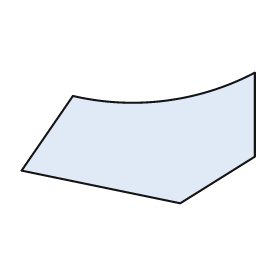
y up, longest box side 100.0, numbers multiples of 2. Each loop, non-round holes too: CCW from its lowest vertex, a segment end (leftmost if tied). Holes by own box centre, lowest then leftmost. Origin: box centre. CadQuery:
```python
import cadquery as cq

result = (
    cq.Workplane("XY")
    .moveTo(18.0, -28.0)
    .lineTo(50.0, -8.0)
    .lineTo(50.0, 28.0)
    .threePointArc((12.0, 16.0), (-28.0, 18.0))
    .lineTo(-50.0, -14.0)
    .close()
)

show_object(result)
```